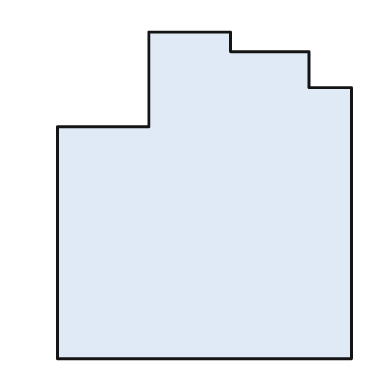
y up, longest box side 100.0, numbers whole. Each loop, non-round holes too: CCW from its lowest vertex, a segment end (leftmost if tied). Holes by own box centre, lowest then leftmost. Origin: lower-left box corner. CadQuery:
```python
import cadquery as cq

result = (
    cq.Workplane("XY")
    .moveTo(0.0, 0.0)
    .lineTo(90.0, 0.0)
    .lineTo(90.0, 83.0)
    .lineTo(77.0, 83.0)
    .lineTo(77.0, 94.0)
    .lineTo(53.0, 94.0)
    .lineTo(53.0, 100.0)
    .lineTo(28.0, 100.0)
    .lineTo(28.0, 71.0)
    .lineTo(0.0, 71.0)
    .close()
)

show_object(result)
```